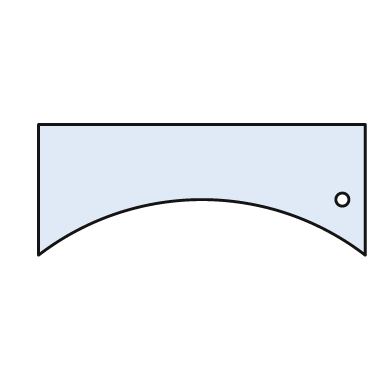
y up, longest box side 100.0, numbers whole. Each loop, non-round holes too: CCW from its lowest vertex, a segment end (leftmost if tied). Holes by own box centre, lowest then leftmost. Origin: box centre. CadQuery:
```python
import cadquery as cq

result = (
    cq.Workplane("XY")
    .moveTo(-50.0, -20.0)
    .threePointArc((0.0, -3.0), (50.0, -20.0))
    .lineTo(50.0, 20.0)
    .lineTo(-50.0, 20.0)
    .close()
    .moveTo(43.0, -3.0)
    .circle(2.0)
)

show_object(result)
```